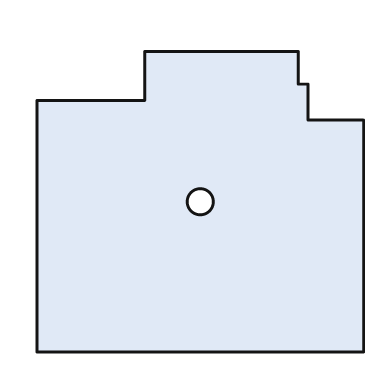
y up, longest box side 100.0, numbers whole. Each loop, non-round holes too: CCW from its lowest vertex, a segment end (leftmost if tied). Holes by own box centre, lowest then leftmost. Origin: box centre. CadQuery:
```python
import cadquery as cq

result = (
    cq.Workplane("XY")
    .moveTo(-50.0, -46.0)
    .lineTo(50.0, -46.0)
    .lineTo(50.0, 25.0)
    .lineTo(33.0, 25.0)
    .lineTo(33.0, 36.0)
    .lineTo(30.0, 36.0)
    .lineTo(30.0, 46.0)
    .lineTo(-17.0, 46.0)
    .lineTo(-17.0, 31.0)
    .lineTo(-50.0, 31.0)
    .close()
    .moveTo(0.0, 0.0)
    .circle(4.0)
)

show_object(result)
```